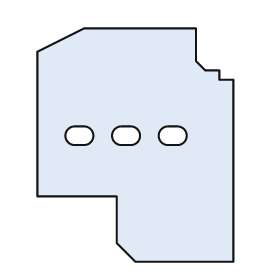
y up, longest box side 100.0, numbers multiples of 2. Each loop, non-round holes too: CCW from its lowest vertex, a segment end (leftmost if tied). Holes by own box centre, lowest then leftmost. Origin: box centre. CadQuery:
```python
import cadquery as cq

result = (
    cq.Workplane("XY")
    .moveTo(0.0, -50.0)
    .lineTo(42.0, -50.0)
    .lineTo(42.0, 28.0)
    .lineTo(36.0, 28.0)
    .lineTo(36.0, 32.0)
    .lineTo(30.0, 32.0)
    .lineTo(26.0, 36.0)
    .lineTo(26.0, 50.0)
    .lineTo(-22.0, 50.0)
    .lineTo(-42.0, 40.0)
    .lineTo(-42.0, -22.0)
    .lineTo(-8.0, -22.0)
    .lineTo(-8.0, -42.0)
    .close()
    .moveTo(-26.0, 0.0)
    .lineTo(-22.0, 0.0)
    .threePointArc((-18.0, 4.0), (-22.0, 8.0))
    .lineTo(-26.0, 8.0)
    .threePointArc((-30.0, 4.0), (-26.0, 0.0))
    .close()
    .moveTo(-6.0, 0.0)
    .lineTo(-2.0, 0.0)
    .threePointArc((2.0, 4.0), (-2.0, 8.0))
    .lineTo(-6.0, 8.0)
    .threePointArc((-10.0, 4.0), (-6.0, 0.0))
    .close()
    .moveTo(14.0, 0.0)
    .lineTo(18.0, 0.0)
    .threePointArc((22.0, 4.0), (18.0, 8.0))
    .lineTo(14.0, 8.0)
    .threePointArc((10.0, 4.0), (14.0, 0.0))
    .close()
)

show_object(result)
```